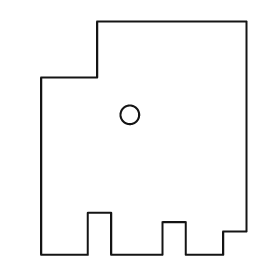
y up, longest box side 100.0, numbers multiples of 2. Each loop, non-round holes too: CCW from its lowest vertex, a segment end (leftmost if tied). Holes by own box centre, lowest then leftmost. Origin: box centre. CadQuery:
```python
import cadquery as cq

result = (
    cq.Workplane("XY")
    .moveTo(-44.0, -50.0)
    .lineTo(-24.0, -50.0)
    .lineTo(-24.0, -32.0)
    .lineTo(-14.0, -32.0)
    .lineTo(-14.0, -50.0)
    .lineTo(8.0, -50.0)
    .lineTo(8.0, -36.0)
    .lineTo(18.0, -36.0)
    .lineTo(18.0, -50.0)
    .lineTo(34.0, -50.0)
    .lineTo(34.0, -40.0)
    .lineTo(44.0, -40.0)
    .lineTo(44.0, 50.0)
    .lineTo(-20.0, 50.0)
    .lineTo(-20.0, 26.0)
    .lineTo(-44.0, 26.0)
    .close()
    .moveTo(-6.0, 10.0)
    .circle(4.0)
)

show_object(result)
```